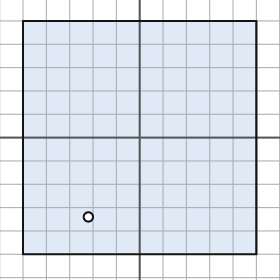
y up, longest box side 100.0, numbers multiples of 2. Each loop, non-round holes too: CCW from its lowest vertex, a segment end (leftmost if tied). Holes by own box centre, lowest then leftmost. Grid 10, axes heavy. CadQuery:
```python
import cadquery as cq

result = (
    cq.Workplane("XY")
    .moveTo(-50.0, -50.0)
    .lineTo(50.0, -50.0)
    .lineTo(50.0, 50.0)
    .lineTo(-50.0, 50.0)
    .close()
    .moveTo(-22.0, -34.0)
    .circle(2.0)
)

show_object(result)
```